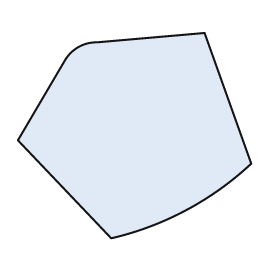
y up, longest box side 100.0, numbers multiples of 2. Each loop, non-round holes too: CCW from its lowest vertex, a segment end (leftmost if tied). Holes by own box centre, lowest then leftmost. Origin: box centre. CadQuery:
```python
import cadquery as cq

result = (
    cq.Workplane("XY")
    .moveTo(-10.0, -44.0)
    .threePointArc((22.0, -32.0), (50.0, -12.0))
    .lineTo(30.0, 44.0)
    .lineTo(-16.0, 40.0)
    .threePointArc((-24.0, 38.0), (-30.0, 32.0))
    .lineTo(-50.0, -2.0)
    .close()
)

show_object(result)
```